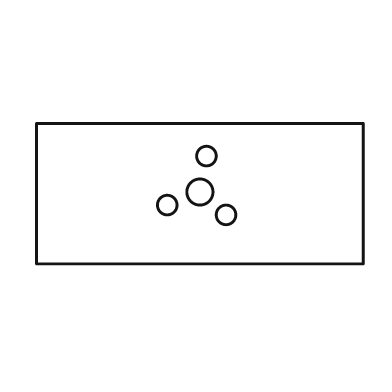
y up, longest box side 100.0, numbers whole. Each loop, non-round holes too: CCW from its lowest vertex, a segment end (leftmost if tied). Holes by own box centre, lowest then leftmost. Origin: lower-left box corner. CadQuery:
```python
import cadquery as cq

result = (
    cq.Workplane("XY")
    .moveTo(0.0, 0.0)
    .lineTo(100.0, 0.0)
    .lineTo(100.0, 43.0)
    .lineTo(0.0, 43.0)
    .close()
    .moveTo(58.0, 15.0)
    .circle(3.0)
    .moveTo(40.0, 18.0)
    .circle(3.0)
    .moveTo(50.0, 22.0)
    .circle(4.0)
    .moveTo(52.0, 33.0)
    .circle(3.0)
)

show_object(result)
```